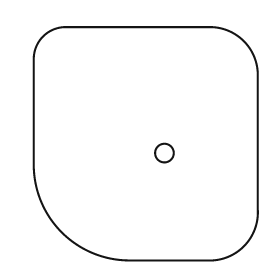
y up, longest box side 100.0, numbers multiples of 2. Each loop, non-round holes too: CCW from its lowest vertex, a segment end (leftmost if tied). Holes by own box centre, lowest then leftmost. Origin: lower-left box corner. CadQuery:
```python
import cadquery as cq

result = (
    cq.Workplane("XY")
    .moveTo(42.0, 0.0)
    .lineTo(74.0, 0.0)
    .threePointArc((90.0, 6.0), (96.0, 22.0))
    .lineTo(96.0, 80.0)
    .threePointArc((90.0, 94.0), (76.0, 100.0))
    .lineTo(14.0, 100.0)
    .threePointArc((4.0, 96.0), (0.0, 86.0))
    .lineTo(0.0, 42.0)
    .threePointArc((12.0, 12.0), (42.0, 0.0))
    .close()
    .moveTo(56.0, 46.0)
    .circle(4.0)
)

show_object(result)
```